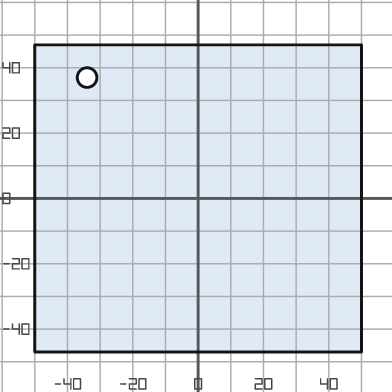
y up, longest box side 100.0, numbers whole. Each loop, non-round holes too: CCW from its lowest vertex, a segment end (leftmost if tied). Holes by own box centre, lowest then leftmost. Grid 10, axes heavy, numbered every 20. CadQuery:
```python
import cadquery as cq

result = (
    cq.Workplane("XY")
    .moveTo(-50.0, -47.0)
    .lineTo(50.0, -47.0)
    .lineTo(50.0, 47.0)
    .lineTo(-50.0, 47.0)
    .close()
    .moveTo(-34.0, 37.0)
    .circle(3.0)
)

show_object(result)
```